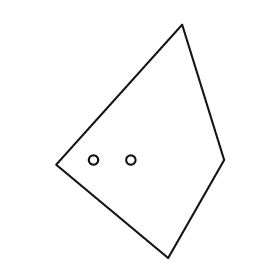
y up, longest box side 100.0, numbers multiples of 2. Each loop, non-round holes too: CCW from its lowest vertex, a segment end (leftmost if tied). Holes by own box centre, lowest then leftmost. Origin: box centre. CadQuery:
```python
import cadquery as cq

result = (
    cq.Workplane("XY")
    .moveTo(12.0, -50.0)
    .lineTo(36.0, -8.0)
    .lineTo(18.0, 50.0)
    .lineTo(-36.0, -10.0)
    .close()
    .moveTo(-20.0, -8.0)
    .circle(2.0)
    .moveTo(-4.0, -8.0)
    .circle(2.0)
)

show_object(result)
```